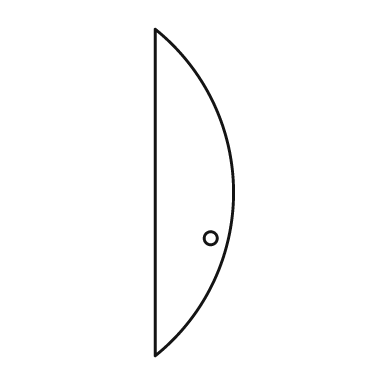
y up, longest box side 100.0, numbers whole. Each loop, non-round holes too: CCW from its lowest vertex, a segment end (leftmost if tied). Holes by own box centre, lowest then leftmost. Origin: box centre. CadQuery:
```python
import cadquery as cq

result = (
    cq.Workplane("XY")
    .moveTo(-12.0, -50.0)
    .threePointArc((12.0, 0.0), (-12.0, 50.0))
    .close()
    .moveTo(5.0, -14.0)
    .circle(2.0)
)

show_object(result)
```